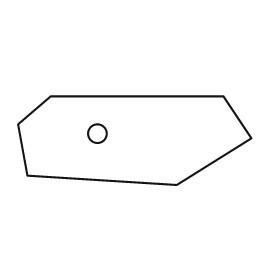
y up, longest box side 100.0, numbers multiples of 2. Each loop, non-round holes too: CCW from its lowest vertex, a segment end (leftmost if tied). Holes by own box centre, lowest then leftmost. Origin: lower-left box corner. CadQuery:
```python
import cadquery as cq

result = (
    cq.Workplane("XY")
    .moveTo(68.0, 0.0)
    .lineTo(100.0, 20.0)
    .lineTo(88.0, 38.0)
    .lineTo(14.0, 38.0)
    .lineTo(0.0, 26.0)
    .lineTo(4.0, 4.0)
    .close()
    .moveTo(34.0, 22.0)
    .circle(4.0)
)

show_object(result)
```